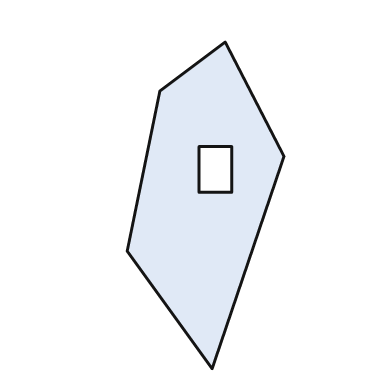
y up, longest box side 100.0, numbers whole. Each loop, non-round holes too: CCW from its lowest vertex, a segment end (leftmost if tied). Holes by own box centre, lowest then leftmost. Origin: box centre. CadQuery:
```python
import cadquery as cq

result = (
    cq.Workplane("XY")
    .moveTo(2.0, -50.0)
    .lineTo(24.0, 15.0)
    .lineTo(6.0, 50.0)
    .lineTo(-14.0, 35.0)
    .lineTo(-24.0, -14.0)
    .close()
    .moveTo(-2.0, 4.0)
    .lineTo(8.0, 4.0)
    .lineTo(8.0, 18.0)
    .lineTo(-2.0, 18.0)
    .close()
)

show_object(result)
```